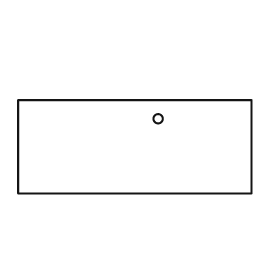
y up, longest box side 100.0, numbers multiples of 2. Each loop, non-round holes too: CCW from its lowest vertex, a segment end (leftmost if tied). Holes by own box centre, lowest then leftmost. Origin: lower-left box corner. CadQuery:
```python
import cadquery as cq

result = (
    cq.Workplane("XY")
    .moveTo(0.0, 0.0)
    .lineTo(100.0, 0.0)
    .lineTo(100.0, 40.0)
    .lineTo(0.0, 40.0)
    .close()
    .moveTo(60.0, 32.0)
    .circle(2.0)
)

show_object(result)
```